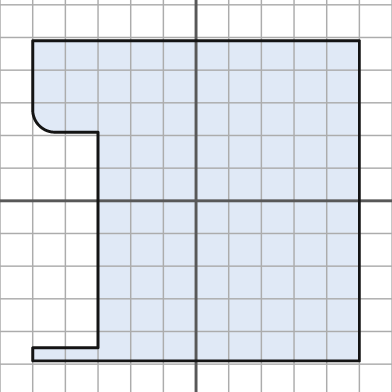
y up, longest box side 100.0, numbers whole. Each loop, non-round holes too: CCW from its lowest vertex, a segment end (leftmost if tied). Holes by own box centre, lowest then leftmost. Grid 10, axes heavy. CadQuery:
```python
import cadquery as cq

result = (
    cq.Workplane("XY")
    .moveTo(-50.0, -49.0)
    .lineTo(50.0, -49.0)
    .lineTo(50.0, 49.0)
    .lineTo(-50.0, 49.0)
    .lineTo(-50.0, 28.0)
    .threePointArc((-48.0, 23.0), (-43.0, 21.0))
    .lineTo(-30.0, 21.0)
    .lineTo(-30.0, -45.0)
    .lineTo(-50.0, -45.0)
    .close()
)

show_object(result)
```